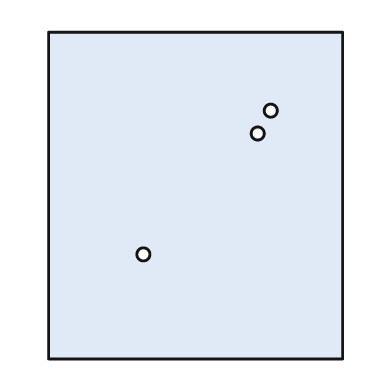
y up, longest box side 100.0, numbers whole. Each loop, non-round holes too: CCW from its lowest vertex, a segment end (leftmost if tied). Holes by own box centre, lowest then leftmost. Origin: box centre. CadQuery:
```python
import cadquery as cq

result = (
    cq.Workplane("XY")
    .moveTo(-45.0, -50.0)
    .lineTo(45.0, -50.0)
    .lineTo(45.0, 50.0)
    .lineTo(-45.0, 50.0)
    .close()
    .moveTo(-16.0, -18.0)
    .circle(2.0)
    .moveTo(19.0, 19.0)
    .circle(2.0)
    .moveTo(23.0, 26.0)
    .circle(2.0)
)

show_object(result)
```